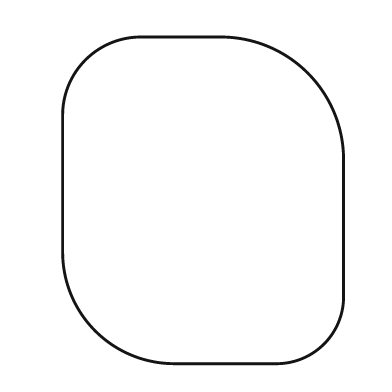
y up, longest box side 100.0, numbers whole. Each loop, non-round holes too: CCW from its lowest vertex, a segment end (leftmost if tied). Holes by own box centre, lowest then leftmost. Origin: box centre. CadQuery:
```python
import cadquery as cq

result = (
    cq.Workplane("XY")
    .moveTo(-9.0, -50.0)
    .lineTo(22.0, -50.0)
    .threePointArc((37.0, -44.0), (43.0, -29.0))
    .lineTo(43.0, 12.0)
    .threePointArc((32.0, 39.0), (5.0, 50.0))
    .lineTo(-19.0, 50.0)
    .threePointArc((-36.0, 43.0), (-43.0, 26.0))
    .lineTo(-43.0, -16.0)
    .threePointArc((-33.0, -40.0), (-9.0, -50.0))
    .close()
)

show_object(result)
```